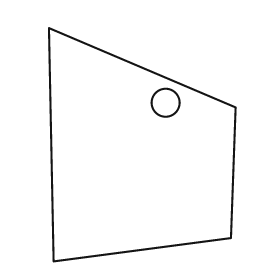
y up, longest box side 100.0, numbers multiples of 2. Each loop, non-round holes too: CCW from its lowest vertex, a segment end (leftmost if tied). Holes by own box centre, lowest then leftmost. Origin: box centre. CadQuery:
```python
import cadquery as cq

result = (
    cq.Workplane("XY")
    .moveTo(-38.0, -50.0)
    .lineTo(38.0, -40.0)
    .lineTo(40.0, 16.0)
    .lineTo(-40.0, 50.0)
    .close()
    .moveTo(10.0, 18.0)
    .circle(6.0)
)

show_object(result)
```